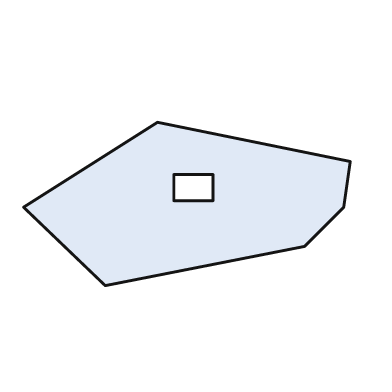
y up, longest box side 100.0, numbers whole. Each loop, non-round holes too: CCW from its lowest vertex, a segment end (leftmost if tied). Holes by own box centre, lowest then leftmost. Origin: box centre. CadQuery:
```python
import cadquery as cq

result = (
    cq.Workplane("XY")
    .moveTo(-25.0, -25.0)
    .lineTo(36.0, -13.0)
    .lineTo(48.0, -1.0)
    .lineTo(50.0, 13.0)
    .lineTo(-9.0, 25.0)
    .lineTo(-50.0, -1.0)
    .close()
    .moveTo(-4.0, 1.0)
    .lineTo(8.0, 1.0)
    .lineTo(8.0, 9.0)
    .lineTo(-4.0, 9.0)
    .close()
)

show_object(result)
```